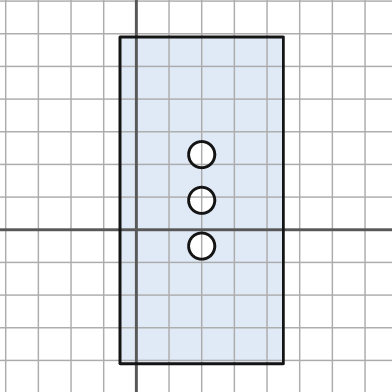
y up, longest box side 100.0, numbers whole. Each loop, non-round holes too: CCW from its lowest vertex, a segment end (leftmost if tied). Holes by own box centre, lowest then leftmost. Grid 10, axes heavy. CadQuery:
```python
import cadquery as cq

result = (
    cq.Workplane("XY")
    .moveTo(-5.0, -41.0)
    .lineTo(45.0, -41.0)
    .lineTo(45.0, 59.0)
    .lineTo(-5.0, 59.0)
    .close()
    .moveTo(20.0, -5.0)
    .circle(4.0)
    .moveTo(20.0, 9.0)
    .circle(4.0)
    .moveTo(20.0, 23.0)
    .circle(4.0)
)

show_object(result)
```